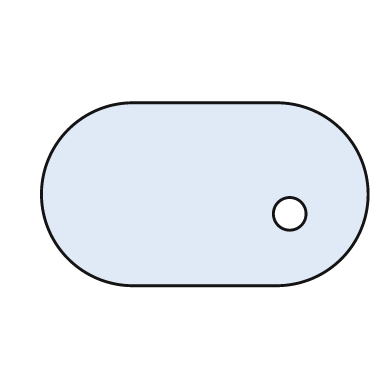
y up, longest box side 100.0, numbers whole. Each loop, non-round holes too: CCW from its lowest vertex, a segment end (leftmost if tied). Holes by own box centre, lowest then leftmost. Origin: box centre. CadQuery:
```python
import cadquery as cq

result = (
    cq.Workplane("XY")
    .moveTo(-22.0, -28.0)
    .lineTo(22.0, -28.0)
    .threePointArc((50.0, 0.0), (22.0, 28.0))
    .lineTo(-22.0, 28.0)
    .threePointArc((-50.0, 0.0), (-22.0, -28.0))
    .close()
    .moveTo(26.0, -6.0)
    .circle(5.0)
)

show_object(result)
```